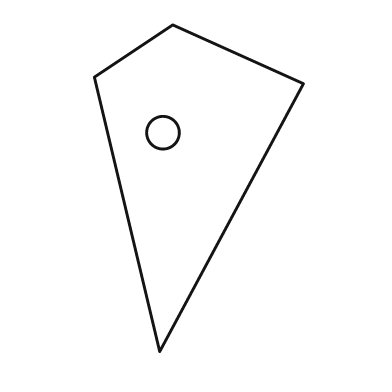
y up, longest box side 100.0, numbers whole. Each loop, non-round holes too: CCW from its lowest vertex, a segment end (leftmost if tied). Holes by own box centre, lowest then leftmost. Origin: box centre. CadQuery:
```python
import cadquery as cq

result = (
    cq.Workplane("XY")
    .moveTo(-12.0, -50.0)
    .lineTo(32.0, 32.0)
    .lineTo(-8.0, 50.0)
    .lineTo(-32.0, 34.0)
    .close()
    .moveTo(-11.0, 17.0)
    .circle(5.0)
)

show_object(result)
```